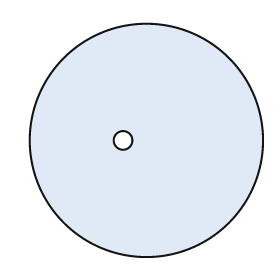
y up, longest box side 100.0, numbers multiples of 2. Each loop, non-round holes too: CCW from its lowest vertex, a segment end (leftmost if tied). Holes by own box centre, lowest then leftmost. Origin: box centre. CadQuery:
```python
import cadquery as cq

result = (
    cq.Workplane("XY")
    .moveTo(0.0, 0.0)
    .circle(50.0)
    .moveTo(-10.0, 0.0)
    .circle(4.0)
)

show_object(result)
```